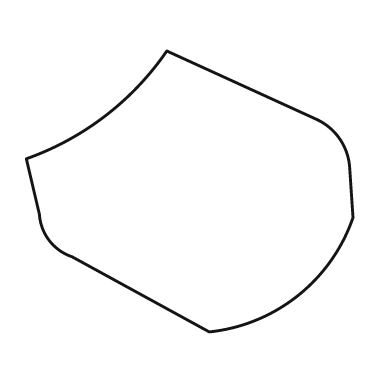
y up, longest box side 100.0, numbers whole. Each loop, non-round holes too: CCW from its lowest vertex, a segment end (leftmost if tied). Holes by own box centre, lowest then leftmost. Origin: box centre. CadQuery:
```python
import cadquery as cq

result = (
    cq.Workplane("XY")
    .moveTo(6.0, -43.0)
    .threePointArc((33.0, -32.0), (50.0, -8.0))
    .lineTo(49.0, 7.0)
    .threePointArc((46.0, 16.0), (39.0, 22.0))
    .lineTo(-7.0, 43.0)
    .threePointArc((-26.0, 23.0), (-50.0, 10.0))
    .lineTo(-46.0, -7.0)
    .threePointArc((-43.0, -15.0), (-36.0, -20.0))
    .close()
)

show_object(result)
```